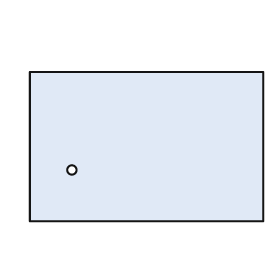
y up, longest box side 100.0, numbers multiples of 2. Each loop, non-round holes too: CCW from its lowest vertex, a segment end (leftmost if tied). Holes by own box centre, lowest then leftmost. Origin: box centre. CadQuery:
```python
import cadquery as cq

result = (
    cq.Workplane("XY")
    .moveTo(-50.0, -32.0)
    .lineTo(50.0, -32.0)
    .lineTo(50.0, 32.0)
    .lineTo(-50.0, 32.0)
    .close()
    .moveTo(-32.0, -10.0)
    .circle(2.0)
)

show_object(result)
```